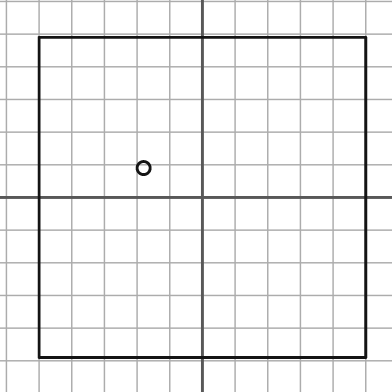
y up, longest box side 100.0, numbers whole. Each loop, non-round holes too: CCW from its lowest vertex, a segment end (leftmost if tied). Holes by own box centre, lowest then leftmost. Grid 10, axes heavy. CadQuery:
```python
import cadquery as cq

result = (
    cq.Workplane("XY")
    .moveTo(-50.0, -49.0)
    .lineTo(50.0, -49.0)
    .lineTo(50.0, 49.0)
    .lineTo(-50.0, 49.0)
    .close()
    .moveTo(-18.0, 9.0)
    .circle(2.0)
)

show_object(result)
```